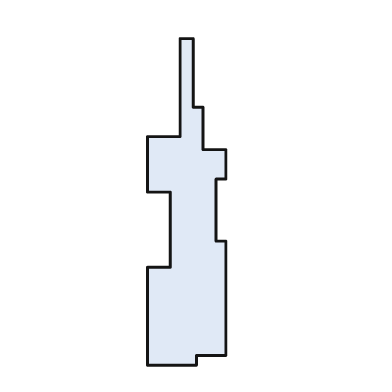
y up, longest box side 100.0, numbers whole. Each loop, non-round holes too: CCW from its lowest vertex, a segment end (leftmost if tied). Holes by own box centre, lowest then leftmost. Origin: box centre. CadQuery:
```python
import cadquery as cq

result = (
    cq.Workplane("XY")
    .moveTo(-12.0, -50.0)
    .lineTo(3.0, -50.0)
    .lineTo(3.0, -47.0)
    .lineTo(12.0, -47.0)
    .lineTo(12.0, -12.0)
    .lineTo(9.0, -12.0)
    .lineTo(9.0, 7.0)
    .lineTo(12.0, 7.0)
    .lineTo(12.0, 16.0)
    .lineTo(5.0, 16.0)
    .lineTo(5.0, 29.0)
    .lineTo(2.0, 29.0)
    .lineTo(2.0, 50.0)
    .lineTo(-2.0, 50.0)
    .lineTo(-2.0, 20.0)
    .lineTo(-12.0, 20.0)
    .lineTo(-12.0, 3.0)
    .lineTo(-5.0, 3.0)
    .lineTo(-5.0, -20.0)
    .lineTo(-12.0, -20.0)
    .close()
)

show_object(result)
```